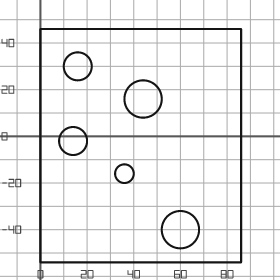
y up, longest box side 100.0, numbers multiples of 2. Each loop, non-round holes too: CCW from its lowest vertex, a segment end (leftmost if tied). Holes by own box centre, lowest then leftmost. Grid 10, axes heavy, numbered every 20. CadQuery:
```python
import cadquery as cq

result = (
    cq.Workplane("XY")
    .moveTo(0.0, -54.0)
    .lineTo(86.0, -54.0)
    .lineTo(86.0, 46.0)
    .lineTo(0.0, 46.0)
    .close()
    .moveTo(60.0, -40.0)
    .circle(8.0)
    .moveTo(36.0, -16.0)
    .circle(4.0)
    .moveTo(14.0, -2.0)
    .circle(6.0)
    .moveTo(44.0, 16.0)
    .circle(8.0)
    .moveTo(16.0, 30.0)
    .circle(6.0)
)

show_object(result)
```